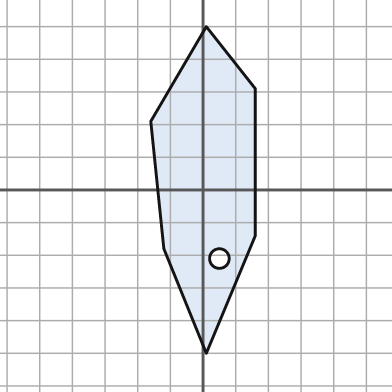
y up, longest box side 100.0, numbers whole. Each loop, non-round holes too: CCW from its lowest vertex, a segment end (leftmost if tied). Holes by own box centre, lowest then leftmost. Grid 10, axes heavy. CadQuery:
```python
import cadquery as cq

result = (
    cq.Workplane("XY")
    .moveTo(1.0, -50.0)
    .lineTo(16.0, -14.0)
    .lineTo(16.0, 31.0)
    .lineTo(1.0, 50.0)
    .lineTo(-16.0, 21.0)
    .lineTo(-12.0, -18.0)
    .close()
    .moveTo(5.0, -21.0)
    .circle(3.0)
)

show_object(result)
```